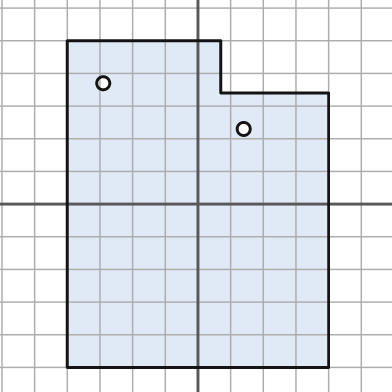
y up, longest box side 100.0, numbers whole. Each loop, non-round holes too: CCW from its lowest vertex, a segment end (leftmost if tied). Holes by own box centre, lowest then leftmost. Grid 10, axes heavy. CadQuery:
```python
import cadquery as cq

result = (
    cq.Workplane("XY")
    .moveTo(-40.0, -50.0)
    .lineTo(40.0, -50.0)
    .lineTo(40.0, 34.0)
    .lineTo(7.0, 34.0)
    .lineTo(7.0, 50.0)
    .lineTo(-40.0, 50.0)
    .close()
    .moveTo(14.0, 23.0)
    .circle(2.0)
    .moveTo(-29.0, 37.0)
    .circle(2.0)
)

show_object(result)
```